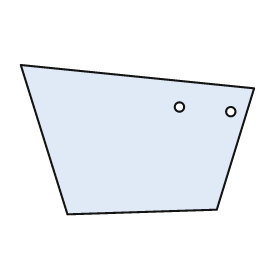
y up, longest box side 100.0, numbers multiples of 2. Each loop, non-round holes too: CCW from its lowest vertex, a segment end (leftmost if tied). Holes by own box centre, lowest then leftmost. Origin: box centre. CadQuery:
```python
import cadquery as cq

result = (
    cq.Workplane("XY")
    .moveTo(-30.0, -32.0)
    .lineTo(34.0, -30.0)
    .lineTo(50.0, 22.0)
    .lineTo(-50.0, 32.0)
    .close()
    .moveTo(40.0, 12.0)
    .circle(2.0)
    .moveTo(18.0, 14.0)
    .circle(2.0)
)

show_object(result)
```